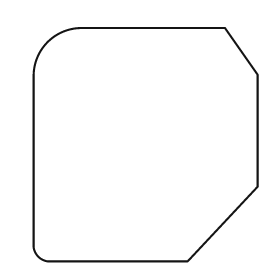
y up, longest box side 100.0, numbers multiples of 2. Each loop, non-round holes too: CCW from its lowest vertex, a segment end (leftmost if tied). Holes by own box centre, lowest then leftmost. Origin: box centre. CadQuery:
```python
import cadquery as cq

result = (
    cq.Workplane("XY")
    .moveTo(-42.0, -50.0)
    .lineTo(18.0, -50.0)
    .lineTo(48.0, -18.0)
    .lineTo(48.0, 30.0)
    .lineTo(34.0, 50.0)
    .lineTo(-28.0, 50.0)
    .threePointArc((-42.0, 44.0), (-48.0, 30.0))
    .lineTo(-48.0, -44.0)
    .threePointArc((-46.0, -48.0), (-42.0, -50.0))
    .close()
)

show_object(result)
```